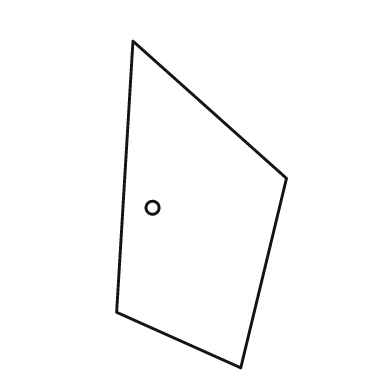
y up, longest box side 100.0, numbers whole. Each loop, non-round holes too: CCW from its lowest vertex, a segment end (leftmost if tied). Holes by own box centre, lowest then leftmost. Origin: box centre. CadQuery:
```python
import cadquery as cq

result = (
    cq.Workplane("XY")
    .moveTo(12.0, -50.0)
    .lineTo(26.0, 8.0)
    .lineTo(-21.0, 50.0)
    .lineTo(-26.0, -33.0)
    .close()
    .moveTo(-15.0, -1.0)
    .circle(2.0)
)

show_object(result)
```